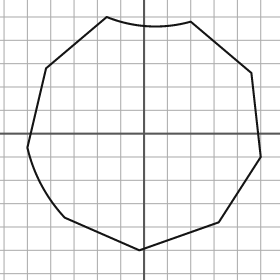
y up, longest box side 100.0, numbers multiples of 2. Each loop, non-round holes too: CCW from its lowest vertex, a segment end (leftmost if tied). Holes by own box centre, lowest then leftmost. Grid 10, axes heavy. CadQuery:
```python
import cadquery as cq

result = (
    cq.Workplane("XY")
    .moveTo(-2.0, -50.0)
    .lineTo(32.0, -38.0)
    .lineTo(50.0, -10.0)
    .lineTo(46.0, 26.0)
    .lineTo(20.0, 48.0)
    .threePointArc((2.0, 46.0), (-16.0, 50.0))
    .lineTo(-42.0, 28.0)
    .lineTo(-50.0, -6.0)
    .threePointArc((-44.0, -22.0), (-34.0, -36.0))
    .close()
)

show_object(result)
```